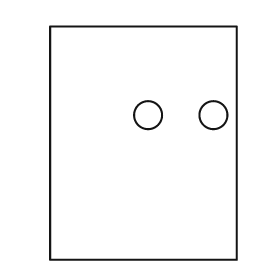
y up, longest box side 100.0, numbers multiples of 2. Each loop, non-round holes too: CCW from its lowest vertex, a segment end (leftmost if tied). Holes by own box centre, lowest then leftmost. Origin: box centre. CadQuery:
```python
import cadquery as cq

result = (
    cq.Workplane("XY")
    .moveTo(-40.0, -50.0)
    .lineTo(40.0, -50.0)
    .lineTo(40.0, 50.0)
    .lineTo(-40.0, 50.0)
    .close()
    .moveTo(2.0, 12.0)
    .circle(6.0)
    .moveTo(30.0, 12.0)
    .circle(6.0)
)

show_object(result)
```